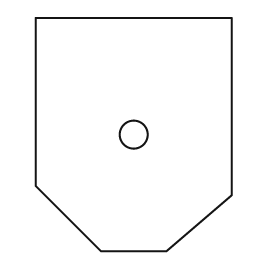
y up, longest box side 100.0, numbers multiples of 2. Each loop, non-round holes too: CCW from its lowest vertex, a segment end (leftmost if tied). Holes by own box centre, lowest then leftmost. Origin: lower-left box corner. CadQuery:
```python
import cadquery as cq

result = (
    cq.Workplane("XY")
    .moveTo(28.0, 0.0)
    .lineTo(56.0, 0.0)
    .lineTo(84.0, 24.0)
    .lineTo(84.0, 100.0)
    .lineTo(0.0, 100.0)
    .lineTo(0.0, 28.0)
    .close()
    .moveTo(42.0, 50.0)
    .circle(6.0)
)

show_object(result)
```